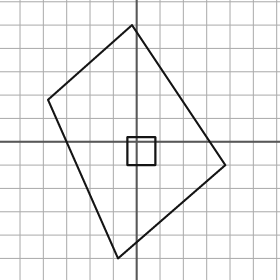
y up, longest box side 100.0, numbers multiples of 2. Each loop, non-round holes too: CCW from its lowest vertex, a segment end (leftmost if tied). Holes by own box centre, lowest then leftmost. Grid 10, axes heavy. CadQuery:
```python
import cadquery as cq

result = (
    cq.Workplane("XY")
    .moveTo(-8.0, -50.0)
    .lineTo(38.0, -10.0)
    .lineTo(-2.0, 50.0)
    .lineTo(-38.0, 18.0)
    .close()
    .moveTo(-4.0, -10.0)
    .lineTo(8.0, -10.0)
    .lineTo(8.0, 2.0)
    .lineTo(-4.0, 2.0)
    .close()
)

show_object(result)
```